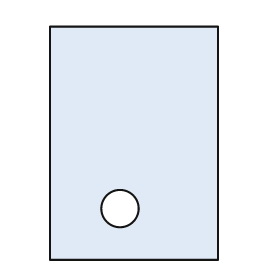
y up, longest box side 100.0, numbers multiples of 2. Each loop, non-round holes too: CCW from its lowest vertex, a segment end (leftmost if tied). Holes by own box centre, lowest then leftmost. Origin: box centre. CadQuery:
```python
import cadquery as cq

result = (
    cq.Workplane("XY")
    .moveTo(-36.0, -50.0)
    .lineTo(36.0, -50.0)
    .lineTo(36.0, 50.0)
    .lineTo(-36.0, 50.0)
    .close()
    .moveTo(-6.0, -28.0)
    .circle(8.0)
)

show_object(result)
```